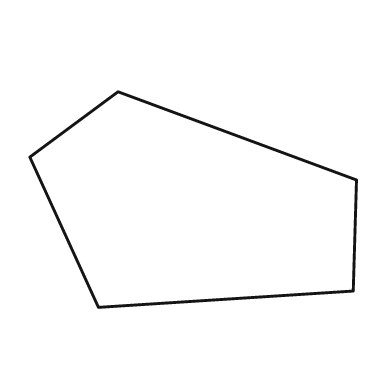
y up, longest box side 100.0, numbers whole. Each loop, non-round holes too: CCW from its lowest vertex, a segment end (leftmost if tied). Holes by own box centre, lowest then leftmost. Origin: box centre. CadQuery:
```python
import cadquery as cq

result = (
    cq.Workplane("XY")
    .moveTo(-29.0, -33.0)
    .lineTo(49.0, -28.0)
    .lineTo(50.0, 6.0)
    .lineTo(-23.0, 33.0)
    .lineTo(-50.0, 13.0)
    .close()
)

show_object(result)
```